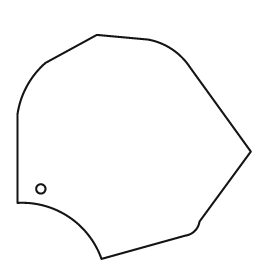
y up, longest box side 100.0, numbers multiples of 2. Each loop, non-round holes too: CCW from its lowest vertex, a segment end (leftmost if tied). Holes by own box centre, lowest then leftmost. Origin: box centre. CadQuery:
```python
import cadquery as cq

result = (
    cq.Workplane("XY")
    .moveTo(-14.0, -48.0)
    .lineTo(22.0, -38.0)
    .threePointArc((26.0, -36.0), (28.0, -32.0))
    .lineTo(50.0, -2.0)
    .lineTo(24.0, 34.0)
    .threePointArc((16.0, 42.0), (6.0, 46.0))
    .lineTo(-16.0, 48.0)
    .lineTo(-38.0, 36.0)
    .threePointArc((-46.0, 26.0), (-50.0, 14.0))
    .lineTo(-50.0, -24.0)
    .threePointArc((-28.0, -30.0), (-14.0, -48.0))
    .close()
    .moveTo(-40.0, -18.0)
    .circle(2.0)
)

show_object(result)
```